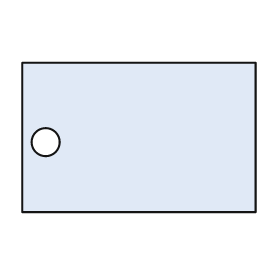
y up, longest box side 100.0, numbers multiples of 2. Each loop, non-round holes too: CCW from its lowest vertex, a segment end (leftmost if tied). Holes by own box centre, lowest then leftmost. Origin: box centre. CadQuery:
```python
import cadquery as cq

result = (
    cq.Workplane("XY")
    .moveTo(-50.0, -32.0)
    .lineTo(50.0, -32.0)
    .lineTo(50.0, 32.0)
    .lineTo(-50.0, 32.0)
    .close()
    .moveTo(-40.0, -2.0)
    .circle(6.0)
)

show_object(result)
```